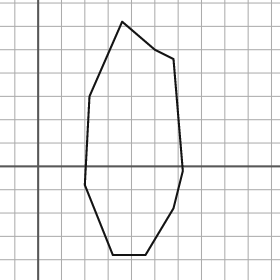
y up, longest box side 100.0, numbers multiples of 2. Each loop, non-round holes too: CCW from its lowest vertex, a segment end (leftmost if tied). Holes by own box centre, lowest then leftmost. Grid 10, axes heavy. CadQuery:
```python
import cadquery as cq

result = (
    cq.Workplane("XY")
    .moveTo(32.0, -38.0)
    .lineTo(46.0, -38.0)
    .lineTo(58.0, -18.0)
    .lineTo(62.0, -2.0)
    .lineTo(58.0, 46.0)
    .lineTo(50.0, 50.0)
    .lineTo(36.0, 62.0)
    .lineTo(22.0, 30.0)
    .lineTo(20.0, -8.0)
    .close()
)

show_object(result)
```